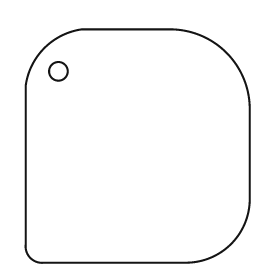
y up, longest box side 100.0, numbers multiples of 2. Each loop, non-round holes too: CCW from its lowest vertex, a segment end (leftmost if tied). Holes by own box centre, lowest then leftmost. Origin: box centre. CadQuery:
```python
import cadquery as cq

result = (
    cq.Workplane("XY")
    .moveTo(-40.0, -50.0)
    .lineTo(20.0, -50.0)
    .threePointArc((40.0, -42.0), (48.0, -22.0))
    .lineTo(48.0, 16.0)
    .threePointArc((38.0, 40.0), (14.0, 50.0))
    .lineTo(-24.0, 50.0)
    .threePointArc((-40.0, 42.0), (-48.0, 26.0))
    .lineTo(-48.0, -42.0)
    .threePointArc((-46.0, -48.0), (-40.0, -50.0))
    .close()
    .moveTo(-34.0, 32.0)
    .circle(4.0)
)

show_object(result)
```